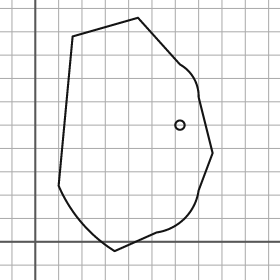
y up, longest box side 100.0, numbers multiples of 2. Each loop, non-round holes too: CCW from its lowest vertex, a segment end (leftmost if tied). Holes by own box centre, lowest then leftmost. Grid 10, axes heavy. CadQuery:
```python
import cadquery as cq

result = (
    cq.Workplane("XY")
    .moveTo(34.0, -4.0)
    .lineTo(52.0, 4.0)
    .threePointArc((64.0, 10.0), (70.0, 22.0))
    .lineTo(76.0, 38.0)
    .lineTo(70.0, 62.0)
    .threePointArc((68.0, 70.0), (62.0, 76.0))
    .lineTo(44.0, 96.0)
    .lineTo(16.0, 88.0)
    .lineTo(10.0, 24.0)
    .threePointArc((20.0, 8.0), (34.0, -4.0))
    .close()
    .moveTo(62.0, 50.0)
    .circle(2.0)
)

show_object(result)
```